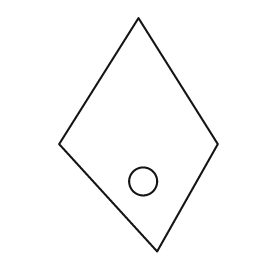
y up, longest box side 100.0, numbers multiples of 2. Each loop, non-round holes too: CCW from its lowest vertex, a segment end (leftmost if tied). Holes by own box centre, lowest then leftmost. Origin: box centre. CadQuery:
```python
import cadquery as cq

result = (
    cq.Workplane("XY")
    .moveTo(8.0, -50.0)
    .lineTo(34.0, -4.0)
    .lineTo(0.0, 50.0)
    .lineTo(-34.0, -4.0)
    .close()
    .moveTo(2.0, -20.0)
    .circle(6.0)
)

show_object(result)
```